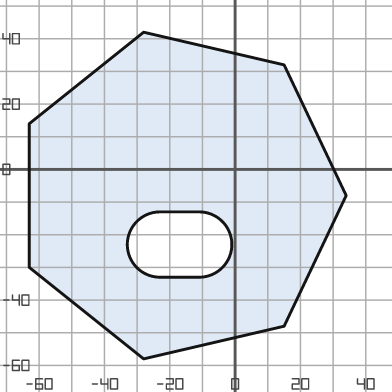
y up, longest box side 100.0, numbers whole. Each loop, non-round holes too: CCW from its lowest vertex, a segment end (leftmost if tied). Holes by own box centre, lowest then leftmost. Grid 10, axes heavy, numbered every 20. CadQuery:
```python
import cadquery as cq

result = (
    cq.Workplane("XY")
    .moveTo(-28.0, -58.0)
    .lineTo(15.0, -48.0)
    .lineTo(34.0, -8.0)
    .lineTo(15.0, 32.0)
    .lineTo(-28.0, 42.0)
    .lineTo(-63.0, 14.0)
    .lineTo(-63.0, -30.0)
    .close()
    .moveTo(-23.0, -33.0)
    .lineTo(-11.0, -33.0)
    .threePointArc((-1.0, -23.0), (-11.0, -13.0))
    .lineTo(-23.0, -13.0)
    .threePointArc((-33.0, -23.0), (-23.0, -33.0))
    .close()
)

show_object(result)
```